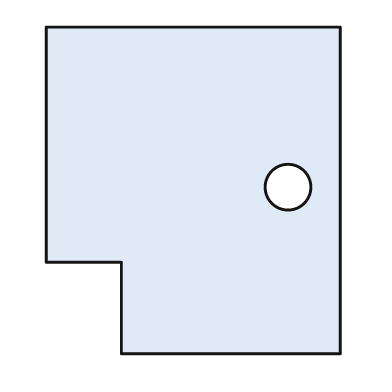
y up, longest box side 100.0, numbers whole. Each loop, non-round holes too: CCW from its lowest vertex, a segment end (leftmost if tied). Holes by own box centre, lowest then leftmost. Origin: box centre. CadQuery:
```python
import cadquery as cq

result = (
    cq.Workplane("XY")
    .moveTo(-22.0, -50.0)
    .lineTo(45.0, -50.0)
    .lineTo(45.0, 50.0)
    .lineTo(-45.0, 50.0)
    .lineTo(-45.0, -22.0)
    .lineTo(-22.0, -22.0)
    .close()
    .moveTo(29.0, 1.0)
    .circle(7.0)
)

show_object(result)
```